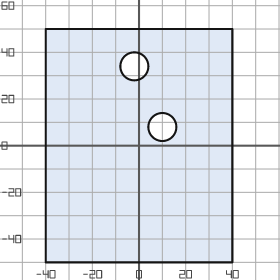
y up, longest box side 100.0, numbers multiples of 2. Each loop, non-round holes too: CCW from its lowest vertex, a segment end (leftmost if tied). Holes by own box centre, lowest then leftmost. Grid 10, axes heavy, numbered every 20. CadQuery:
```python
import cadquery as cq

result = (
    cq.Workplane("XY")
    .moveTo(-40.0, -50.0)
    .lineTo(40.0, -50.0)
    .lineTo(40.0, 50.0)
    .lineTo(-40.0, 50.0)
    .close()
    .moveTo(10.0, 8.0)
    .circle(6.0)
    .moveTo(-2.0, 34.0)
    .circle(6.0)
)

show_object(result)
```